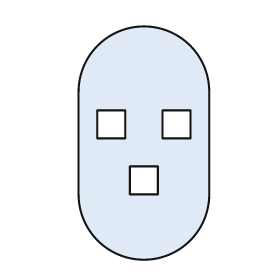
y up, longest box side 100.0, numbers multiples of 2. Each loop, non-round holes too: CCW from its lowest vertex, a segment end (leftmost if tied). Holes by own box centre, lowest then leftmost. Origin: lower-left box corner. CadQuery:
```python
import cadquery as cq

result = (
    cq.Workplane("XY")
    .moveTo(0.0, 28.0)
    .threePointArc((28.0, 0.0), (56.0, 28.0))
    .lineTo(56.0, 72.0)
    .threePointArc((28.0, 100.0), (0.0, 72.0))
    .close()
    .moveTo(22.0, 28.0)
    .lineTo(34.0, 28.0)
    .lineTo(34.0, 40.0)
    .lineTo(22.0, 40.0)
    .close()
    .moveTo(8.0, 52.0)
    .lineTo(20.0, 52.0)
    .lineTo(20.0, 64.0)
    .lineTo(8.0, 64.0)
    .close()
    .moveTo(36.0, 52.0)
    .lineTo(48.0, 52.0)
    .lineTo(48.0, 64.0)
    .lineTo(36.0, 64.0)
    .close()
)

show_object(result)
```